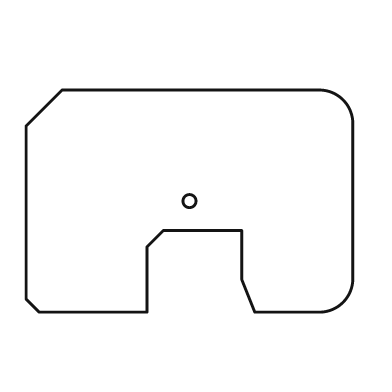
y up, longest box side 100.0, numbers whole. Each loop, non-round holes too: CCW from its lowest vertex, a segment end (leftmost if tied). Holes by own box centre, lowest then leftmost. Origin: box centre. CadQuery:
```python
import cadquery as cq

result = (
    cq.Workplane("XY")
    .moveTo(-46.0, -34.0)
    .lineTo(-13.0, -34.0)
    .lineTo(-13.0, -14.0)
    .lineTo(-8.0, -9.0)
    .lineTo(16.0, -9.0)
    .lineTo(16.0, -24.0)
    .lineTo(20.0, -34.0)
    .lineTo(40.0, -34.0)
    .threePointArc((47.0, -31.0), (50.0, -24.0))
    .lineTo(50.0, 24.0)
    .threePointArc((47.0, 31.0), (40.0, 34.0))
    .lineTo(-39.0, 34.0)
    .lineTo(-50.0, 23.0)
    .lineTo(-50.0, -30.0)
    .close()
    .moveTo(0.0, 0.0)
    .circle(2.0)
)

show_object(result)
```